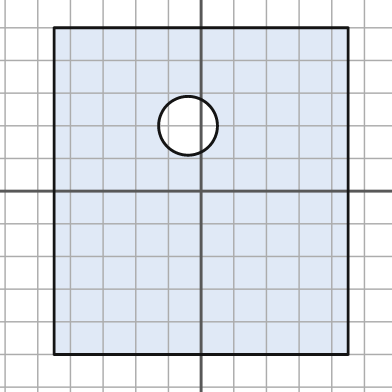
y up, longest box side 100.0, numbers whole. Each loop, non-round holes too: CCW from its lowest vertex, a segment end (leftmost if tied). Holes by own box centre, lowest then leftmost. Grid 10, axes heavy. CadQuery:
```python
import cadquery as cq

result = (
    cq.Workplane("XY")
    .moveTo(-45.0, -50.0)
    .lineTo(45.0, -50.0)
    .lineTo(45.0, 50.0)
    .lineTo(-45.0, 50.0)
    .close()
    .moveTo(-4.0, 20.0)
    .circle(9.0)
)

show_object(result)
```